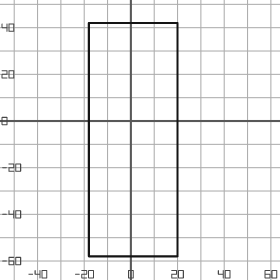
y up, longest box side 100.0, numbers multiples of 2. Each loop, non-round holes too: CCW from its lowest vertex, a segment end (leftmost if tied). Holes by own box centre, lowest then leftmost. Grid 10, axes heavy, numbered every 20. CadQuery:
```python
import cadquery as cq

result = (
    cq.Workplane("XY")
    .moveTo(-18.0, -58.0)
    .lineTo(20.0, -58.0)
    .lineTo(20.0, 42.0)
    .lineTo(-18.0, 42.0)
    .close()
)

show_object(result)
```